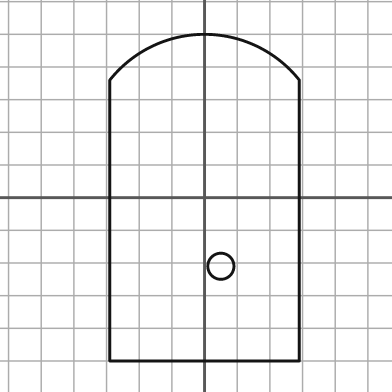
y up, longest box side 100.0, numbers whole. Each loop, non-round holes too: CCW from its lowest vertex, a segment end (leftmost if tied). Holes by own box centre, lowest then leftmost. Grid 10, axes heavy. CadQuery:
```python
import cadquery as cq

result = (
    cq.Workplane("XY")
    .moveTo(-29.0, -50.0)
    .lineTo(29.0, -50.0)
    .lineTo(29.0, 36.0)
    .threePointArc((0.0, 50.0), (-29.0, 36.0))
    .close()
    .moveTo(5.0, -21.0)
    .circle(4.0)
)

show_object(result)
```